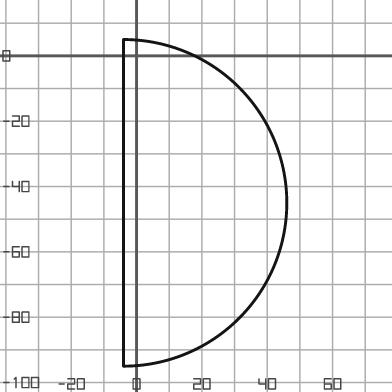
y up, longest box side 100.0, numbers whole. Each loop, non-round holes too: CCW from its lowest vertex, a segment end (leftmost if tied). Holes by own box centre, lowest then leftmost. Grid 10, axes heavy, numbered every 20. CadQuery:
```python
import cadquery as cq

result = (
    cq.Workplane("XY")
    .moveTo(-4.0, -95.0)
    .threePointArc((46.0, -45.0), (-4.0, 5.0))
    .close()
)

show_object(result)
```